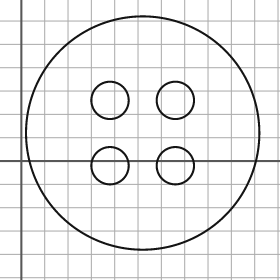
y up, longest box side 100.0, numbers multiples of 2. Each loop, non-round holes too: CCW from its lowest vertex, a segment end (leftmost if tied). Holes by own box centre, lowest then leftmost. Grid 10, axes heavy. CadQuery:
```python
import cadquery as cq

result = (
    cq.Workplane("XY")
    .moveTo(52.0, 12.0)
    .circle(50.0)
    .moveTo(38.0, -2.0)
    .circle(8.0)
    .moveTo(66.0, -2.0)
    .circle(8.0)
    .moveTo(38.0, 26.0)
    .circle(8.0)
    .moveTo(66.0, 26.0)
    .circle(8.0)
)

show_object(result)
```